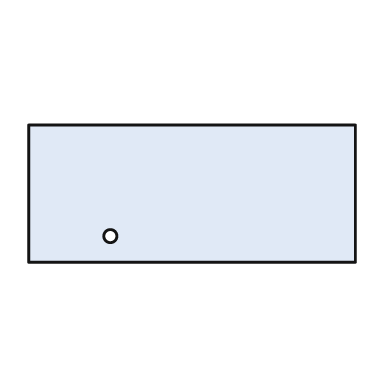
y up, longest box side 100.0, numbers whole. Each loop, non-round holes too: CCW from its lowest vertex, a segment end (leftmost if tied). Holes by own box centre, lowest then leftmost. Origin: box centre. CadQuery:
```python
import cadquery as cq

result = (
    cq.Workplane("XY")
    .moveTo(-50.0, -21.0)
    .lineTo(50.0, -21.0)
    .lineTo(50.0, 21.0)
    .lineTo(-50.0, 21.0)
    .close()
    .moveTo(-25.0, -13.0)
    .circle(2.0)
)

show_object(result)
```